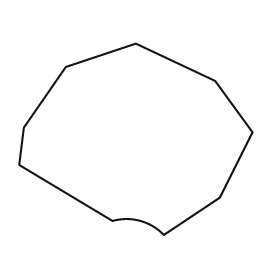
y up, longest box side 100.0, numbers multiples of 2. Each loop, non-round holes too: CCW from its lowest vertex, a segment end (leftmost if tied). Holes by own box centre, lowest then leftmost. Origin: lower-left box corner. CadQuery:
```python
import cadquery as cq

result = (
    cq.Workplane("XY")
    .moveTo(62.0, 0.0)
    .lineTo(86.0, 16.0)
    .lineTo(100.0, 44.0)
    .lineTo(84.0, 66.0)
    .lineTo(50.0, 82.0)
    .lineTo(20.0, 72.0)
    .lineTo(2.0, 46.0)
    .lineTo(0.0, 30.0)
    .lineTo(40.0, 6.0)
    .threePointArc((52.0, 6.0), (62.0, 0.0))
    .close()
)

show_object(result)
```